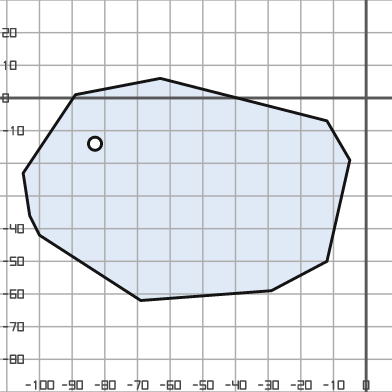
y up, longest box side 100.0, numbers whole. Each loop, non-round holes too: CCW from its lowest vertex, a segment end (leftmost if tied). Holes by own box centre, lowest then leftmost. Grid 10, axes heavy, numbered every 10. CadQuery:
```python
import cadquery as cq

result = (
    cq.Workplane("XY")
    .moveTo(-69.0, -62.0)
    .lineTo(-29.0, -59.0)
    .lineTo(-12.0, -50.0)
    .lineTo(-5.0, -19.0)
    .lineTo(-12.0, -7.0)
    .lineTo(-63.0, 6.0)
    .lineTo(-89.0, 1.0)
    .lineTo(-105.0, -23.0)
    .lineTo(-103.0, -36.0)
    .lineTo(-100.0, -42.0)
    .close()
    .moveTo(-83.0, -14.0)
    .circle(2.0)
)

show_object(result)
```